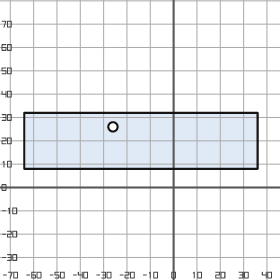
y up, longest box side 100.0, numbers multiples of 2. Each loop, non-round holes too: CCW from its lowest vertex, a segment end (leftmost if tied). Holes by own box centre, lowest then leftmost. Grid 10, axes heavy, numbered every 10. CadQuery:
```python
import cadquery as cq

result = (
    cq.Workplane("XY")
    .moveTo(-64.0, 8.0)
    .lineTo(36.0, 8.0)
    .lineTo(36.0, 32.0)
    .lineTo(-64.0, 32.0)
    .close()
    .moveTo(-26.0, 26.0)
    .circle(2.0)
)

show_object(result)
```